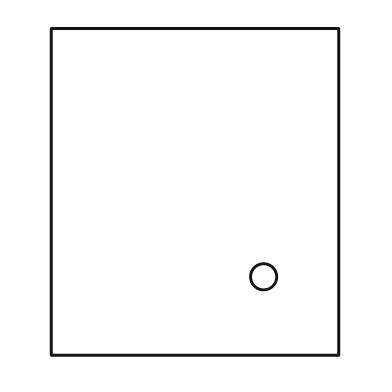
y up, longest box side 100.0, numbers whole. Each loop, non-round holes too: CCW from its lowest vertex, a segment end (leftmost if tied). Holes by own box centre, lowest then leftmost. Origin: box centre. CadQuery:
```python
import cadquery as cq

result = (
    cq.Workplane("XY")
    .moveTo(-44.0, -50.0)
    .lineTo(44.0, -50.0)
    .lineTo(44.0, 50.0)
    .lineTo(-44.0, 50.0)
    .close()
    .moveTo(21.0, -26.0)
    .circle(4.0)
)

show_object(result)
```